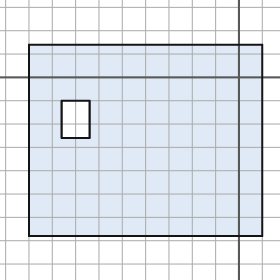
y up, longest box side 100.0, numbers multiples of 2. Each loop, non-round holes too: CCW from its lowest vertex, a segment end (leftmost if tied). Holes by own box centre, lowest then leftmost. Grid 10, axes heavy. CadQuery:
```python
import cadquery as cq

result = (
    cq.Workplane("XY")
    .moveTo(-90.0, -68.0)
    .lineTo(10.0, -68.0)
    .lineTo(10.0, 14.0)
    .lineTo(-90.0, 14.0)
    .close()
    .moveTo(-76.0, -26.0)
    .lineTo(-64.0, -26.0)
    .lineTo(-64.0, -10.0)
    .lineTo(-76.0, -10.0)
    .close()
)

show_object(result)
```